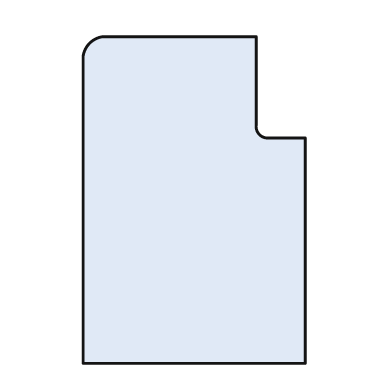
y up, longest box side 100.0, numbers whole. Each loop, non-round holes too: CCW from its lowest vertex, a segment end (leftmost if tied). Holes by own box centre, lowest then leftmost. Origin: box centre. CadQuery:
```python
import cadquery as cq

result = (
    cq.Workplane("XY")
    .moveTo(-34.0, -50.0)
    .lineTo(34.0, -50.0)
    .lineTo(34.0, 19.0)
    .lineTo(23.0, 19.0)
    .threePointArc((20.0, 20.0), (19.0, 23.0))
    .lineTo(19.0, 50.0)
    .lineTo(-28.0, 50.0)
    .threePointArc((-32.0, 48.0), (-34.0, 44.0))
    .close()
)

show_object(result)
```